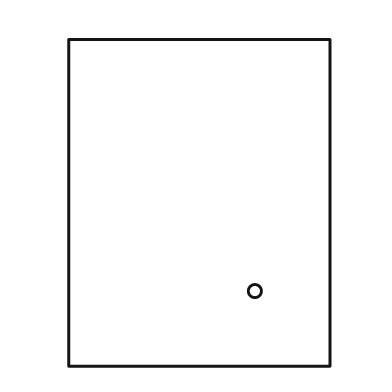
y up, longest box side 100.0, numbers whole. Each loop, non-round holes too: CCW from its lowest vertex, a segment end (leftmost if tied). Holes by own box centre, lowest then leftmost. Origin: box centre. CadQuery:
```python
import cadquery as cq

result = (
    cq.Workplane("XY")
    .moveTo(-40.0, -50.0)
    .lineTo(40.0, -50.0)
    .lineTo(40.0, 50.0)
    .lineTo(-40.0, 50.0)
    .close()
    .moveTo(17.0, -27.0)
    .circle(2.0)
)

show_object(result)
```